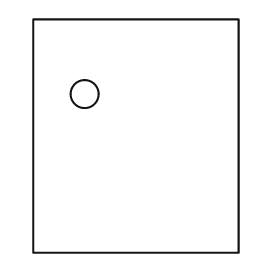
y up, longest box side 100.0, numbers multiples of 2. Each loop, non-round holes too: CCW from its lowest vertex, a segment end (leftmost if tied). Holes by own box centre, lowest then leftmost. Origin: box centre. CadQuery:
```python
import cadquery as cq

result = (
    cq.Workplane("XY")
    .moveTo(-44.0, -50.0)
    .lineTo(44.0, -50.0)
    .lineTo(44.0, 50.0)
    .lineTo(-44.0, 50.0)
    .close()
    .moveTo(-22.0, 18.0)
    .circle(6.0)
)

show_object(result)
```